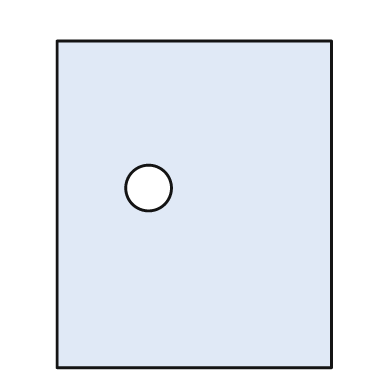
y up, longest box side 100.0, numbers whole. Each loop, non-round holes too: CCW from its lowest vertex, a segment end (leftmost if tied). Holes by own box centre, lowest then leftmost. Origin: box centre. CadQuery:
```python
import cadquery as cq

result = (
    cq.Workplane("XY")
    .moveTo(-42.0, -50.0)
    .lineTo(42.0, -50.0)
    .lineTo(42.0, 50.0)
    .lineTo(-42.0, 50.0)
    .close()
    .moveTo(-14.0, 5.0)
    .circle(7.0)
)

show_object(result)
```